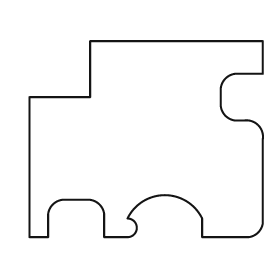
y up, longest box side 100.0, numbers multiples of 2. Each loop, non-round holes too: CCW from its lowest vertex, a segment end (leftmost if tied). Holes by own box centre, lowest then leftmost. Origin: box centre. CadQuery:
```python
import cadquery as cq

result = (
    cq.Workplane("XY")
    .moveTo(-50.0, -42.0)
    .lineTo(-42.0, -42.0)
    .lineTo(-42.0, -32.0)
    .threePointArc((-40.0, -28.0), (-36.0, -26.0))
    .lineTo(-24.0, -26.0)
    .threePointArc((-20.0, -28.0), (-18.0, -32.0))
    .lineTo(-18.0, -42.0)
    .lineTo(-8.0, -42.0)
    .threePointArc((-4.0, -38.0), (-8.0, -34.0))
    .threePointArc((8.0, -24.0), (24.0, -34.0))
    .lineTo(24.0, -42.0)
    .lineTo(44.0, -42.0)
    .threePointArc((48.0, -40.0), (50.0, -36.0))
    .lineTo(50.0, 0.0)
    .threePointArc((48.0, 6.0), (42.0, 8.0))
    .lineTo(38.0, 8.0)
    .threePointArc((34.0, 10.0), (32.0, 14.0))
    .lineTo(32.0, 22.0)
    .threePointArc((34.0, 26.0), (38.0, 28.0))
    .lineTo(50.0, 28.0)
    .lineTo(50.0, 42.0)
    .lineTo(-24.0, 42.0)
    .lineTo(-24.0, 18.0)
    .lineTo(-50.0, 18.0)
    .close()
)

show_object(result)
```